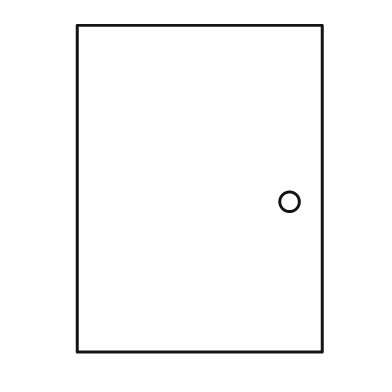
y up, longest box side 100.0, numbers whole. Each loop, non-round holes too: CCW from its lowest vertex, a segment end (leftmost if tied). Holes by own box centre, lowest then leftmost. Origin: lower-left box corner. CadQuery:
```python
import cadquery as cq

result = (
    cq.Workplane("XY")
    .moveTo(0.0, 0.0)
    .lineTo(75.0, 0.0)
    .lineTo(75.0, 100.0)
    .lineTo(0.0, 100.0)
    .close()
    .moveTo(65.0, 46.0)
    .circle(3.0)
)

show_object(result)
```